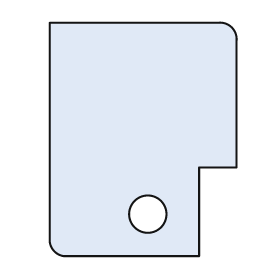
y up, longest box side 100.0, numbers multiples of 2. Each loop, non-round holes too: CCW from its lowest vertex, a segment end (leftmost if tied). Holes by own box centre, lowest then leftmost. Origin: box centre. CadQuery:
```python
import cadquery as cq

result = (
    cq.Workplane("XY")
    .moveTo(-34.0, -50.0)
    .lineTo(24.0, -50.0)
    .lineTo(24.0, -12.0)
    .lineTo(40.0, -12.0)
    .lineTo(40.0, 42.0)
    .threePointArc((38.0, 48.0), (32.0, 50.0))
    .lineTo(-40.0, 50.0)
    .lineTo(-40.0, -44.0)
    .threePointArc((-38.0, -48.0), (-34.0, -50.0))
    .close()
    .moveTo(2.0, -32.0)
    .circle(8.0)
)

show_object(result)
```